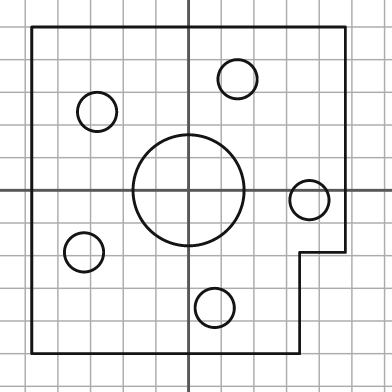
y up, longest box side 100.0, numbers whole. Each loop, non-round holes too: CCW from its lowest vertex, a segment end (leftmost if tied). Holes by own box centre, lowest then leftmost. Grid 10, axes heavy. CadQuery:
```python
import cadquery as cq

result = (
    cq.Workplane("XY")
    .moveTo(-48.0, -50.0)
    .lineTo(34.0, -50.0)
    .lineTo(34.0, -19.0)
    .lineTo(48.0, -19.0)
    .lineTo(48.0, 50.0)
    .lineTo(-48.0, 50.0)
    .close()
    .moveTo(8.0, -36.0)
    .circle(6.0)
    .moveTo(-32.0, -19.0)
    .circle(6.0)
    .moveTo(37.0, -3.0)
    .circle(6.0)
    .moveTo(0.0, 0.0)
    .circle(17.0)
    .moveTo(-28.0, 24.0)
    .circle(6.0)
    .moveTo(15.0, 34.0)
    .circle(6.0)
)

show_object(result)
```